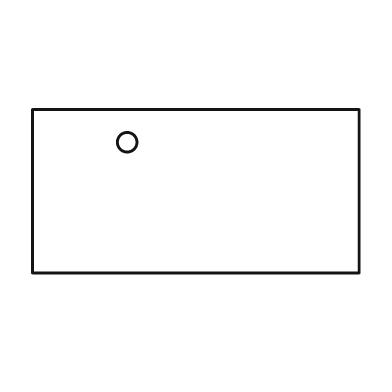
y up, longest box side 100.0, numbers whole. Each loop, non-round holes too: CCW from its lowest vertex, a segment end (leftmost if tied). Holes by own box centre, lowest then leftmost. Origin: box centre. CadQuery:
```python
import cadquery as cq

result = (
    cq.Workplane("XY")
    .moveTo(-50.0, -25.0)
    .lineTo(50.0, -25.0)
    .lineTo(50.0, 25.0)
    .lineTo(-50.0, 25.0)
    .close()
    .moveTo(-21.0, 15.0)
    .circle(3.0)
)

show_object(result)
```